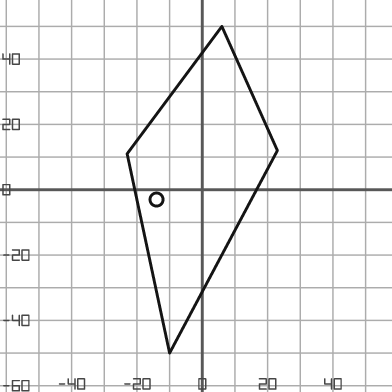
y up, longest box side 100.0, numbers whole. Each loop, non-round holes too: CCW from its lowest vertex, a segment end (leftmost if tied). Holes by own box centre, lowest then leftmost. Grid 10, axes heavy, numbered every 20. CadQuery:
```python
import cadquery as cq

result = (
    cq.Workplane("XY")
    .moveTo(-10.0, -50.0)
    .lineTo(23.0, 12.0)
    .lineTo(6.0, 50.0)
    .lineTo(-23.0, 11.0)
    .close()
    .moveTo(-14.0, -3.0)
    .circle(2.0)
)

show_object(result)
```